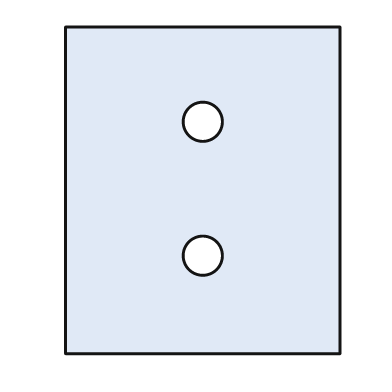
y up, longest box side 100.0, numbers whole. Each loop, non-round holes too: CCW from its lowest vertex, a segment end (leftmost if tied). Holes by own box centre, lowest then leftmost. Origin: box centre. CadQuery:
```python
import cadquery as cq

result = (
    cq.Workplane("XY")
    .moveTo(-42.0, -50.0)
    .lineTo(42.0, -50.0)
    .lineTo(42.0, 50.0)
    .lineTo(-42.0, 50.0)
    .close()
    .moveTo(0.0, -20.0)
    .circle(6.0)
    .moveTo(0.0, 21.0)
    .circle(6.0)
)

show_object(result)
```